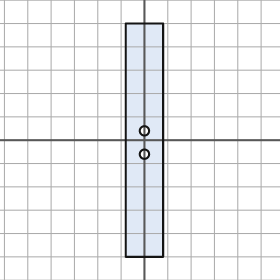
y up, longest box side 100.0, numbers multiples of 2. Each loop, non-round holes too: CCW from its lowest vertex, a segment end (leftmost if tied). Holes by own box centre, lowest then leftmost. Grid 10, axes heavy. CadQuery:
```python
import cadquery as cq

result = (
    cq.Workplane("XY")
    .moveTo(-8.0, -50.0)
    .lineTo(8.0, -50.0)
    .lineTo(8.0, 50.0)
    .lineTo(-8.0, 50.0)
    .close()
    .moveTo(0.0, -6.0)
    .circle(2.0)
    .moveTo(0.0, 4.0)
    .circle(2.0)
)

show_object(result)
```